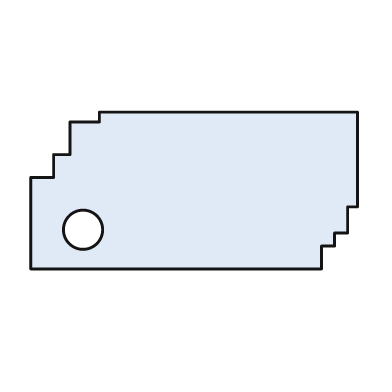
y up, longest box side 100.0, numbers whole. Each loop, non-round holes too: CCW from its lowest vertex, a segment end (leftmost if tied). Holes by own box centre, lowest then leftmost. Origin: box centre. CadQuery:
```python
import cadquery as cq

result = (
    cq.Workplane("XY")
    .moveTo(-50.0, -24.0)
    .lineTo(39.0, -24.0)
    .lineTo(39.0, -17.0)
    .lineTo(43.0, -17.0)
    .lineTo(43.0, -13.0)
    .lineTo(47.0, -13.0)
    .lineTo(47.0, -5.0)
    .lineTo(50.0, -5.0)
    .lineTo(50.0, 24.0)
    .lineTo(-29.0, 24.0)
    .lineTo(-29.0, 21.0)
    .lineTo(-38.0, 21.0)
    .lineTo(-38.0, 11.0)
    .lineTo(-43.0, 11.0)
    .lineTo(-43.0, 4.0)
    .lineTo(-50.0, 4.0)
    .close()
    .moveTo(-34.0, -12.0)
    .circle(6.0)
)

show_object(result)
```